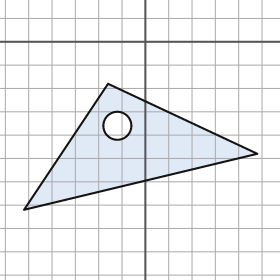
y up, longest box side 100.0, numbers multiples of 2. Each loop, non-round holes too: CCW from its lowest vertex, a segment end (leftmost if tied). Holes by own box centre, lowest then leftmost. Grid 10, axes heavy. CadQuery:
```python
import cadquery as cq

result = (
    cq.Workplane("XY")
    .moveTo(-52.0, -72.0)
    .lineTo(48.0, -48.0)
    .lineTo(-16.0, -18.0)
    .close()
    .moveTo(-12.0, -36.0)
    .circle(6.0)
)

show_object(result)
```